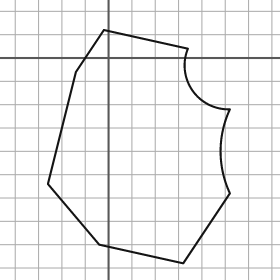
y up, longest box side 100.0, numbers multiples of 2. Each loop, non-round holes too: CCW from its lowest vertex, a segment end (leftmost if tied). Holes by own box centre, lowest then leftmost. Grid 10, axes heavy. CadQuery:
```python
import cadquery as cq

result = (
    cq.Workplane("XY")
    .moveTo(32.0, -88.0)
    .lineTo(52.0, -58.0)
    .threePointArc((48.0, -40.0), (52.0, -22.0))
    .threePointArc((36.0, -14.0), (34.0, 4.0))
    .lineTo(-2.0, 12.0)
    .lineTo(-14.0, -6.0)
    .lineTo(-26.0, -54.0)
    .lineTo(-4.0, -80.0)
    .close()
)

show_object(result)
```